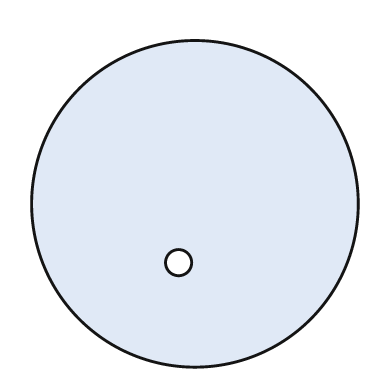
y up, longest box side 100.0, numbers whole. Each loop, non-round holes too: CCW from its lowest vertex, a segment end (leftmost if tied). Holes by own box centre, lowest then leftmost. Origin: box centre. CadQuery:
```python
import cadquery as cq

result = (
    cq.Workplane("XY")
    .moveTo(0.0, 0.0)
    .circle(50.0)
    .moveTo(-5.0, -18.0)
    .circle(4.0)
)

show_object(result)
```